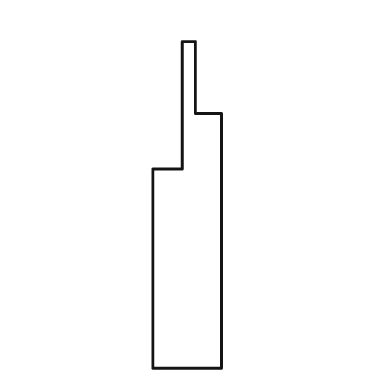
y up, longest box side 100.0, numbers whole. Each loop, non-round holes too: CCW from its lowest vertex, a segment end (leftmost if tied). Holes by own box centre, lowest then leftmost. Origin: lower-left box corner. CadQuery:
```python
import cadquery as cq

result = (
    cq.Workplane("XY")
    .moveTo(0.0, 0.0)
    .lineTo(21.0, 0.0)
    .lineTo(21.0, 78.0)
    .lineTo(13.0, 78.0)
    .lineTo(13.0, 100.0)
    .lineTo(9.0, 100.0)
    .lineTo(9.0, 61.0)
    .lineTo(0.0, 61.0)
    .close()
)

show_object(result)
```